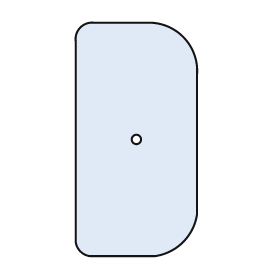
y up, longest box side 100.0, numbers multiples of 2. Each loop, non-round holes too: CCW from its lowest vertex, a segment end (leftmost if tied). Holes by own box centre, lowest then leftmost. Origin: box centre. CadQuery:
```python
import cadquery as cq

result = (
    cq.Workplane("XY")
    .moveTo(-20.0, -50.0)
    .lineTo(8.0, -50.0)
    .threePointArc((20.0, -44.0), (26.0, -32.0))
    .lineTo(26.0, 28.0)
    .threePointArc((20.0, 44.0), (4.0, 50.0))
    .lineTo(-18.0, 50.0)
    .threePointArc((-24.0, 48.0), (-26.0, 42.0))
    .lineTo(-26.0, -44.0)
    .threePointArc((-24.0, -48.0), (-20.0, -50.0))
    .close()
    .moveTo(0.0, 0.0)
    .circle(2.0)
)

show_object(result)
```